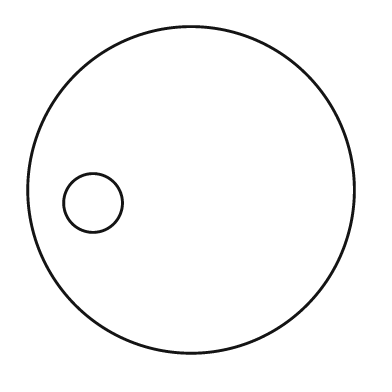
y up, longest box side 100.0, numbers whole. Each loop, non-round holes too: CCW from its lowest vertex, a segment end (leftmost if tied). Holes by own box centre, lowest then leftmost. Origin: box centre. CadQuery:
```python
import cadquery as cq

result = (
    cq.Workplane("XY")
    .moveTo(0.0, 0.0)
    .circle(50.0)
    .moveTo(-30.0, -4.0)
    .circle(9.0)
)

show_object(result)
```